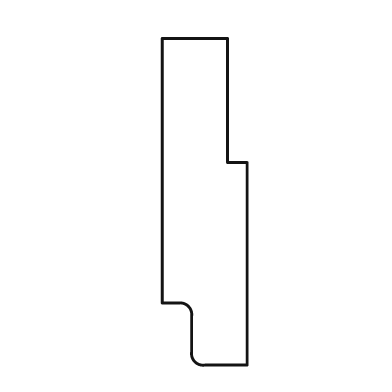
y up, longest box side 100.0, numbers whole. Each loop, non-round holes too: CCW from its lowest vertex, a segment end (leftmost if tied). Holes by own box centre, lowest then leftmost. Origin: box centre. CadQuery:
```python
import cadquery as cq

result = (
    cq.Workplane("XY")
    .moveTo(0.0, -50.0)
    .lineTo(13.0, -50.0)
    .lineTo(13.0, 12.0)
    .lineTo(7.0, 12.0)
    .lineTo(7.0, 50.0)
    .lineTo(-13.0, 50.0)
    .lineTo(-13.0, -31.0)
    .lineTo(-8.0, -31.0)
    .threePointArc((-5.0, -32.0), (-4.0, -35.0))
    .lineTo(-4.0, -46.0)
    .threePointArc((-3.0, -49.0), (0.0, -50.0))
    .close()
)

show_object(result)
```